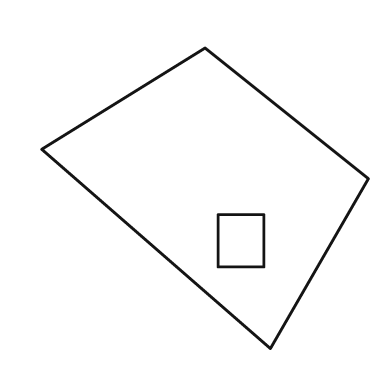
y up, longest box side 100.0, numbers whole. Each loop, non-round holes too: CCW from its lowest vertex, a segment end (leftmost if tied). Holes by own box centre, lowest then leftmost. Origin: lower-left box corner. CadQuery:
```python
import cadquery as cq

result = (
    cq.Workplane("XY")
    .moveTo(70.0, 0.0)
    .lineTo(100.0, 52.0)
    .lineTo(50.0, 92.0)
    .lineTo(0.0, 61.0)
    .close()
    .moveTo(54.0, 25.0)
    .lineTo(68.0, 25.0)
    .lineTo(68.0, 41.0)
    .lineTo(54.0, 41.0)
    .close()
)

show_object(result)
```